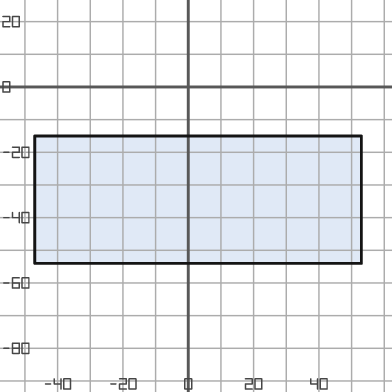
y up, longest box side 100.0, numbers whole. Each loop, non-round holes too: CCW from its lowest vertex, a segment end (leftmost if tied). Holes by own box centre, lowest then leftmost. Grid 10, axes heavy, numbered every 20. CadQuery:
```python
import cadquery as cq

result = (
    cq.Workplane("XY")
    .moveTo(-47.0, -54.0)
    .lineTo(53.0, -54.0)
    .lineTo(53.0, -15.0)
    .lineTo(-47.0, -15.0)
    .close()
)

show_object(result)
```